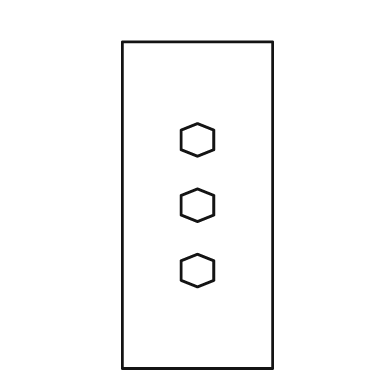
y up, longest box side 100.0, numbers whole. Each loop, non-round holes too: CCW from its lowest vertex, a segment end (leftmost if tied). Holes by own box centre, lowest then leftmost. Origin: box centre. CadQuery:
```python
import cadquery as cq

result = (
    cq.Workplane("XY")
    .moveTo(-23.0, -50.0)
    .lineTo(23.0, -50.0)
    .lineTo(23.0, 50.0)
    .lineTo(-23.0, 50.0)
    .close()
    .moveTo(0.0, -25.0)
    .lineTo(5.0, -23.0)
    .lineTo(5.0, -17.0)
    .lineTo(0.0, -15.0)
    .lineTo(-5.0, -17.0)
    .lineTo(-5.0, -23.0)
    .close()
    .moveTo(0.0, -5.0)
    .lineTo(5.0, -3.0)
    .lineTo(5.0, 3.0)
    .lineTo(0.0, 5.0)
    .lineTo(-5.0, 3.0)
    .lineTo(-5.0, -3.0)
    .close()
    .moveTo(0.0, 15.0)
    .lineTo(5.0, 17.0)
    .lineTo(5.0, 23.0)
    .lineTo(0.0, 25.0)
    .lineTo(-5.0, 23.0)
    .lineTo(-5.0, 17.0)
    .close()
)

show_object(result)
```